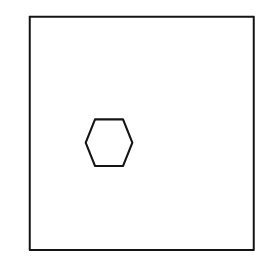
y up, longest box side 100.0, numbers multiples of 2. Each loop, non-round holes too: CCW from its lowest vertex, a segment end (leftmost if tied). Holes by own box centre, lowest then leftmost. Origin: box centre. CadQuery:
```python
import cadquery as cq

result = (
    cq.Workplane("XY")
    .moveTo(-48.0, -50.0)
    .lineTo(48.0, -50.0)
    .lineTo(48.0, 50.0)
    .lineTo(-48.0, 50.0)
    .close()
    .moveTo(-20.0, -14.0)
    .lineTo(-8.0, -14.0)
    .lineTo(-4.0, -4.0)
    .lineTo(-8.0, 6.0)
    .lineTo(-20.0, 6.0)
    .lineTo(-24.0, -4.0)
    .close()
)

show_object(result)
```